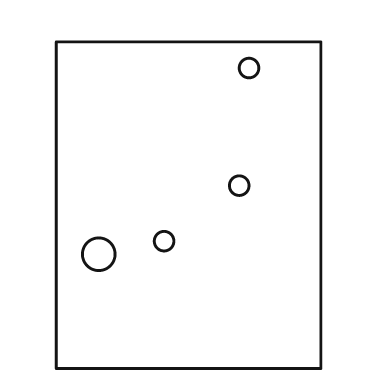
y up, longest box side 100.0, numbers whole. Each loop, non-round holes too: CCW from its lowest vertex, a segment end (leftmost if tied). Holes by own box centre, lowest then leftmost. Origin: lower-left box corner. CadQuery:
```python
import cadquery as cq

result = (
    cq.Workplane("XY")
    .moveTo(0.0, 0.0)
    .lineTo(81.0, 0.0)
    .lineTo(81.0, 100.0)
    .lineTo(0.0, 100.0)
    .close()
    .moveTo(13.0, 35.0)
    .circle(5.0)
    .moveTo(33.0, 39.0)
    .circle(3.0)
    .moveTo(56.0, 56.0)
    .circle(3.0)
    .moveTo(59.0, 92.0)
    .circle(3.0)
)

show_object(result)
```